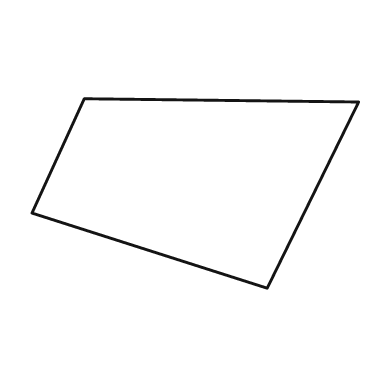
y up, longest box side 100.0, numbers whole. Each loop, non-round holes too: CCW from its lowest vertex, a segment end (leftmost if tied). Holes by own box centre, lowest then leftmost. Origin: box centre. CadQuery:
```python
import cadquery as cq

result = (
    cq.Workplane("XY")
    .moveTo(22.0, -29.0)
    .lineTo(50.0, 28.0)
    .lineTo(-34.0, 29.0)
    .lineTo(-50.0, -6.0)
    .close()
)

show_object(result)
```